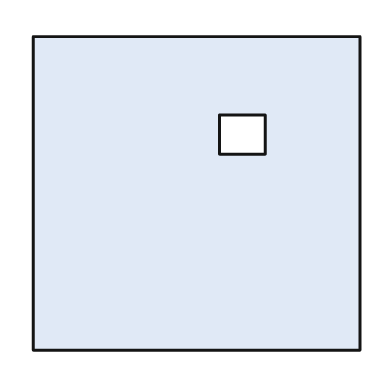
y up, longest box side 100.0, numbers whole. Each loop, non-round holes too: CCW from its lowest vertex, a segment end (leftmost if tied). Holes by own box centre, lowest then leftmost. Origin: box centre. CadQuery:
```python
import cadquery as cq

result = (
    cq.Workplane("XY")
    .moveTo(-50.0, -48.0)
    .lineTo(50.0, -48.0)
    .lineTo(50.0, 48.0)
    .lineTo(-50.0, 48.0)
    .close()
    .moveTo(7.0, 12.0)
    .lineTo(21.0, 12.0)
    .lineTo(21.0, 24.0)
    .lineTo(7.0, 24.0)
    .close()
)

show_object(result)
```